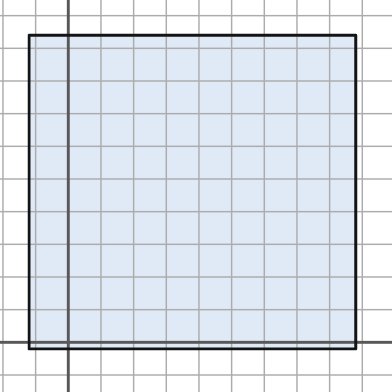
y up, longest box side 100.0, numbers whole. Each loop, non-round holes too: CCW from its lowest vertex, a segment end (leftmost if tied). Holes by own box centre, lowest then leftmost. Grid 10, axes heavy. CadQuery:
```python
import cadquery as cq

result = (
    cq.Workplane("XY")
    .moveTo(-12.0, -2.0)
    .lineTo(88.0, -2.0)
    .lineTo(88.0, 94.0)
    .lineTo(-12.0, 94.0)
    .close()
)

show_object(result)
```